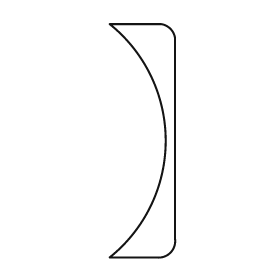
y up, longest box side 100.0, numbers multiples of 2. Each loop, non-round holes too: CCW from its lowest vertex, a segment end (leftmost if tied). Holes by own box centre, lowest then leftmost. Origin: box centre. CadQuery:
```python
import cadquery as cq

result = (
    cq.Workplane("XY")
    .moveTo(-14.0, -50.0)
    .lineTo(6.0, -50.0)
    .threePointArc((12.0, -48.0), (14.0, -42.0))
    .lineTo(14.0, 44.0)
    .threePointArc((12.0, 48.0), (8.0, 50.0))
    .lineTo(-14.0, 50.0)
    .threePointArc((10.0, 0.0), (-14.0, -50.0))
    .close()
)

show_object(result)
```